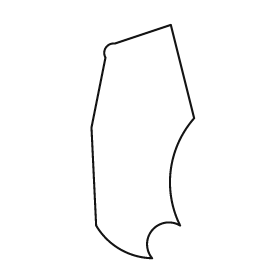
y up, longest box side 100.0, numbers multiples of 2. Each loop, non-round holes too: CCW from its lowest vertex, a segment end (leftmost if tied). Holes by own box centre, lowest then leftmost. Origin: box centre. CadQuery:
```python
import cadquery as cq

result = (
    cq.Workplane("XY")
    .moveTo(4.0, -50.0)
    .threePointArc((4.0, -38.0), (16.0, -36.0))
    .threePointArc((12.0, -12.0), (22.0, 10.0))
    .lineTo(12.0, 50.0)
    .lineTo(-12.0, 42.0)
    .threePointArc((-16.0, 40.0), (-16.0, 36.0))
    .lineTo(-22.0, 6.0)
    .lineTo(-20.0, -36.0)
    .threePointArc((-10.0, -46.0), (4.0, -50.0))
    .close()
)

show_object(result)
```